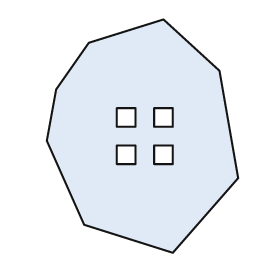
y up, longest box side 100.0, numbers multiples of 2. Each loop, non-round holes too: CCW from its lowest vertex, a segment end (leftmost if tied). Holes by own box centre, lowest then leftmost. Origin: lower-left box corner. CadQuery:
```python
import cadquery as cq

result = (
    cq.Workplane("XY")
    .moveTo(54.0, 0.0)
    .lineTo(82.0, 32.0)
    .lineTo(74.0, 78.0)
    .lineTo(50.0, 100.0)
    .lineTo(18.0, 90.0)
    .lineTo(4.0, 70.0)
    .lineTo(0.0, 48.0)
    .lineTo(16.0, 12.0)
    .close()
    .moveTo(30.0, 38.0)
    .lineTo(38.0, 38.0)
    .lineTo(38.0, 46.0)
    .lineTo(30.0, 46.0)
    .close()
    .moveTo(46.0, 38.0)
    .lineTo(54.0, 38.0)
    .lineTo(54.0, 46.0)
    .lineTo(46.0, 46.0)
    .close()
    .moveTo(30.0, 54.0)
    .lineTo(38.0, 54.0)
    .lineTo(38.0, 62.0)
    .lineTo(30.0, 62.0)
    .close()
    .moveTo(46.0, 54.0)
    .lineTo(54.0, 54.0)
    .lineTo(54.0, 62.0)
    .lineTo(46.0, 62.0)
    .close()
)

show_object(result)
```